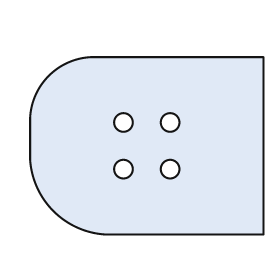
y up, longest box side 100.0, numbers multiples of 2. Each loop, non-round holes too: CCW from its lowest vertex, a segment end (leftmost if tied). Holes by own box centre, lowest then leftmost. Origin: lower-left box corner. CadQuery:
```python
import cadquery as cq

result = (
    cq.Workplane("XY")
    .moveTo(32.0, 0.0)
    .lineTo(100.0, 0.0)
    .lineTo(100.0, 76.0)
    .lineTo(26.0, 76.0)
    .threePointArc((8.0, 68.0), (0.0, 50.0))
    .lineTo(0.0, 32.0)
    .threePointArc((10.0, 10.0), (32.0, 0.0))
    .close()
    .moveTo(40.0, 28.0)
    .circle(4.0)
    .moveTo(60.0, 28.0)
    .circle(4.0)
    .moveTo(40.0, 48.0)
    .circle(4.0)
    .moveTo(60.0, 48.0)
    .circle(4.0)
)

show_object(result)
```